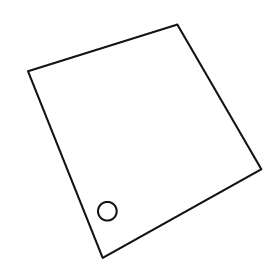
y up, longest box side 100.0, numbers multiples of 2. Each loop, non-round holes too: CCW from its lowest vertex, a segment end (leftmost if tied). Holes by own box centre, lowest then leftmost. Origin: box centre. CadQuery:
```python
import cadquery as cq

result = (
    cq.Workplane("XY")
    .moveTo(-18.0, -50.0)
    .lineTo(50.0, -12.0)
    .lineTo(14.0, 50.0)
    .lineTo(-50.0, 30.0)
    .close()
    .moveTo(-16.0, -30.0)
    .circle(4.0)
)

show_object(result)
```